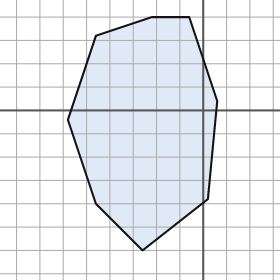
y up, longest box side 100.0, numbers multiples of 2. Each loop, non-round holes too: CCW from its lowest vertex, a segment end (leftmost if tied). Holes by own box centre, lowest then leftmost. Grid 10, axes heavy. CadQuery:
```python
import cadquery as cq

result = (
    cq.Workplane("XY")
    .moveTo(-26.0, -60.0)
    .lineTo(2.0, -38.0)
    .lineTo(6.0, 4.0)
    .lineTo(-6.0, 40.0)
    .lineTo(-22.0, 40.0)
    .lineTo(-46.0, 32.0)
    .lineTo(-58.0, -4.0)
    .lineTo(-46.0, -40.0)
    .close()
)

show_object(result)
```